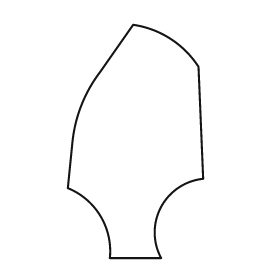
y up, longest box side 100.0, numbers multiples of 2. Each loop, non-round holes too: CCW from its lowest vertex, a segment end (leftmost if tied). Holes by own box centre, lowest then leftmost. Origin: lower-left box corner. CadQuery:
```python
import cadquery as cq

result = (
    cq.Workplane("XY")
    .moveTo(18.0, 0.0)
    .lineTo(40.0, 0.0)
    .threePointArc((40.0, 22.0), (58.0, 34.0))
    .lineTo(56.0, 82.0)
    .threePointArc((44.0, 94.0), (28.0, 100.0))
    .lineTo(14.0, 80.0)
    .threePointArc((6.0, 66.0), (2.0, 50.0))
    .lineTo(0.0, 30.0)
    .threePointArc((14.0, 18.0), (18.0, 0.0))
    .close()
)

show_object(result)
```